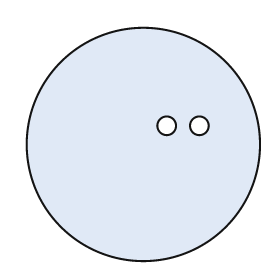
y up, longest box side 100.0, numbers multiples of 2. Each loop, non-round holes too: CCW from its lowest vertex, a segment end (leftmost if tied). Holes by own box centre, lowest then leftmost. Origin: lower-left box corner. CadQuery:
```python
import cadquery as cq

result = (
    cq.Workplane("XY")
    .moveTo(50.0, 50.0)
    .circle(50.0)
    .moveTo(60.0, 58.0)
    .circle(4.0)
    .moveTo(74.0, 58.0)
    .circle(4.0)
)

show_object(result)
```